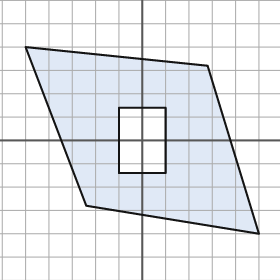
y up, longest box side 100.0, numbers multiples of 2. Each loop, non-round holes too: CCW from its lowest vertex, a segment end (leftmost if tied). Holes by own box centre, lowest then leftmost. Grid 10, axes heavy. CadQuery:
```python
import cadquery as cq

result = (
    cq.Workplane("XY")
    .moveTo(50.0, -40.0)
    .lineTo(28.0, 32.0)
    .lineTo(-50.0, 40.0)
    .lineTo(-24.0, -28.0)
    .close()
    .moveTo(-10.0, -14.0)
    .lineTo(10.0, -14.0)
    .lineTo(10.0, 14.0)
    .lineTo(-10.0, 14.0)
    .close()
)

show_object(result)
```